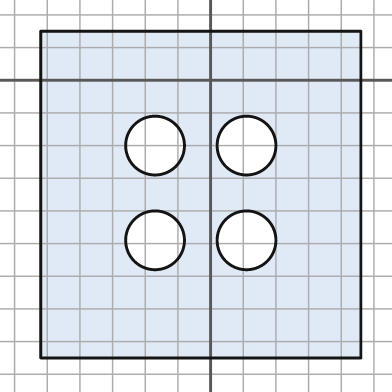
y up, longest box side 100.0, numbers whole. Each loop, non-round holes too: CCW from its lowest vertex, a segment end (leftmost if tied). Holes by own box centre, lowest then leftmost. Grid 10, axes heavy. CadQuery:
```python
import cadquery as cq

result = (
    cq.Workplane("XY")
    .moveTo(-52.0, -85.0)
    .lineTo(46.0, -85.0)
    .lineTo(46.0, 15.0)
    .lineTo(-52.0, 15.0)
    .close()
    .moveTo(-17.0, -49.0)
    .circle(9.0)
    .moveTo(11.0, -49.0)
    .circle(9.0)
    .moveTo(-17.0, -20.0)
    .circle(9.0)
    .moveTo(11.0, -20.0)
    .circle(9.0)
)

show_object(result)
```